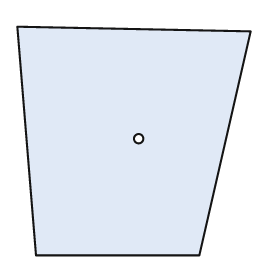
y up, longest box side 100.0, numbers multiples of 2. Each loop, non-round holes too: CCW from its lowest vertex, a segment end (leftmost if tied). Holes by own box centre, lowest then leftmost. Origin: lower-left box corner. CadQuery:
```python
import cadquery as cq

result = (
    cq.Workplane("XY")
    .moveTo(8.0, 0.0)
    .lineTo(78.0, 0.0)
    .lineTo(100.0, 96.0)
    .lineTo(0.0, 98.0)
    .close()
    .moveTo(52.0, 50.0)
    .circle(2.0)
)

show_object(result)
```